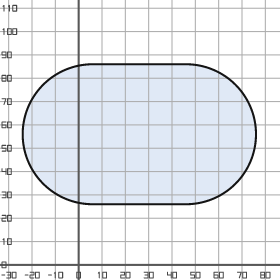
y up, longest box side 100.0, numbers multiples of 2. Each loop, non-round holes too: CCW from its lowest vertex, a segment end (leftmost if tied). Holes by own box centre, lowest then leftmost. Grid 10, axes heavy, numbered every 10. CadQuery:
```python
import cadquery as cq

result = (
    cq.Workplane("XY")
    .moveTo(6.0, 26.0)
    .lineTo(46.0, 26.0)
    .threePointArc((76.0, 56.0), (46.0, 86.0))
    .lineTo(6.0, 86.0)
    .threePointArc((-24.0, 56.0), (6.0, 26.0))
    .close()
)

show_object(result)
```